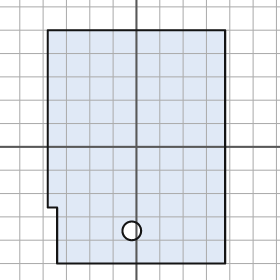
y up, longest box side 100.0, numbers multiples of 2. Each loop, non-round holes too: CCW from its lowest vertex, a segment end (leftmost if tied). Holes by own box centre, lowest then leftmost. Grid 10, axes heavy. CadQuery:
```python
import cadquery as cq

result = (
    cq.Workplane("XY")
    .moveTo(-34.0, -50.0)
    .lineTo(38.0, -50.0)
    .lineTo(38.0, 50.0)
    .lineTo(-38.0, 50.0)
    .lineTo(-38.0, -26.0)
    .lineTo(-34.0, -26.0)
    .close()
    .moveTo(-2.0, -36.0)
    .circle(4.0)
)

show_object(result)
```